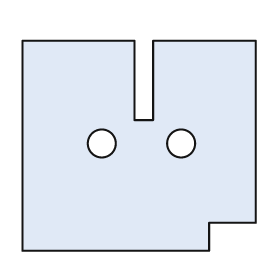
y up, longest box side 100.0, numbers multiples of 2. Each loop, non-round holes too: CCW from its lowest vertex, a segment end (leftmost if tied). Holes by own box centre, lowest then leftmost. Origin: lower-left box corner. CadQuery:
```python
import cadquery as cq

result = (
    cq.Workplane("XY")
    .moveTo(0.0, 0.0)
    .lineTo(80.0, 0.0)
    .lineTo(80.0, 12.0)
    .lineTo(100.0, 12.0)
    .lineTo(100.0, 90.0)
    .lineTo(56.0, 90.0)
    .lineTo(56.0, 56.0)
    .lineTo(48.0, 56.0)
    .lineTo(48.0, 90.0)
    .lineTo(0.0, 90.0)
    .close()
    .moveTo(34.0, 46.0)
    .circle(6.0)
    .moveTo(68.0, 46.0)
    .circle(6.0)
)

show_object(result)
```